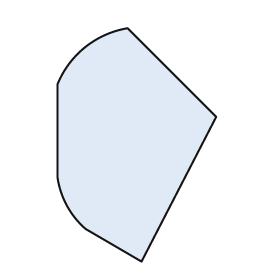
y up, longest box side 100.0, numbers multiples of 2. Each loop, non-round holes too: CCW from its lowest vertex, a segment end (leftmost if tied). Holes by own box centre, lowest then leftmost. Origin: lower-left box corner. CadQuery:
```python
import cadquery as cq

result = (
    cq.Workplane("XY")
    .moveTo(36.0, 0.0)
    .lineTo(68.0, 62.0)
    .lineTo(30.0, 100.0)
    .threePointArc((12.0, 92.0), (0.0, 76.0))
    .lineTo(0.0, 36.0)
    .threePointArc((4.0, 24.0), (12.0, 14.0))
    .close()
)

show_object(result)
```